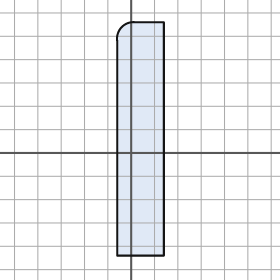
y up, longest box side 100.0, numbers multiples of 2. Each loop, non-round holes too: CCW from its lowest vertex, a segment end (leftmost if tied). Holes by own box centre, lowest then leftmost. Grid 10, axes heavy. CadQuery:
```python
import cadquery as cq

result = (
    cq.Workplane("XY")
    .moveTo(-6.0, -44.0)
    .lineTo(14.0, -44.0)
    .lineTo(14.0, 56.0)
    .lineTo(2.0, 56.0)
    .threePointArc((-4.0, 54.0), (-6.0, 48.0))
    .close()
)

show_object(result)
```